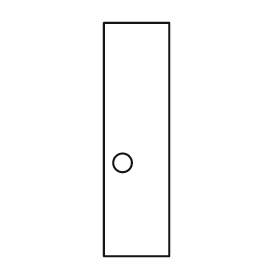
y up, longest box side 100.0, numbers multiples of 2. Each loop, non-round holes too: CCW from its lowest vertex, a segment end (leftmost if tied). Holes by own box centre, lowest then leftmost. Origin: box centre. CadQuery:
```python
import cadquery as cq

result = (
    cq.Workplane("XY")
    .moveTo(-14.0, -50.0)
    .lineTo(14.0, -50.0)
    .lineTo(14.0, 50.0)
    .lineTo(-14.0, 50.0)
    .close()
    .moveTo(-6.0, -10.0)
    .circle(4.0)
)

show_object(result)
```